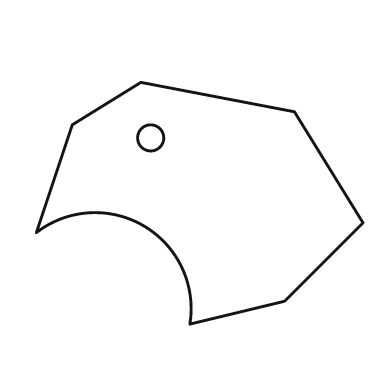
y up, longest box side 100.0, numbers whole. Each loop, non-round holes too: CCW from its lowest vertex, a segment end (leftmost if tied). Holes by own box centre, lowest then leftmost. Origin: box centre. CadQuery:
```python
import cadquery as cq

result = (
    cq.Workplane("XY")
    .moveTo(-3.0, -37.0)
    .lineTo(26.0, -30.0)
    .lineTo(50.0, -6.0)
    .lineTo(29.0, 28.0)
    .lineTo(-18.0, 37.0)
    .lineTo(-39.0, 24.0)
    .lineTo(-50.0, -9.0)
    .threePointArc((-17.0, -7.0), (-3.0, -37.0))
    .close()
    .moveTo(-15.0, 20.0)
    .circle(4.0)
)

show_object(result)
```